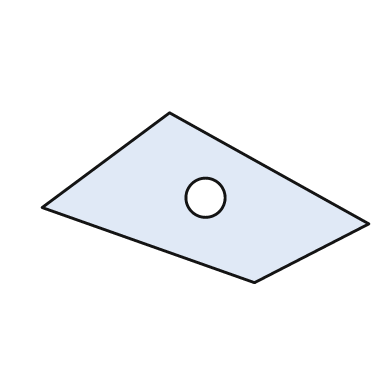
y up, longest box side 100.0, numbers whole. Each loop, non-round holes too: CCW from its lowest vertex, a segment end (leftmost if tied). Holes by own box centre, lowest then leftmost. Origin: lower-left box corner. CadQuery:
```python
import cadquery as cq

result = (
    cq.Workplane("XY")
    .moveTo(65.0, 0.0)
    .lineTo(100.0, 18.0)
    .lineTo(39.0, 52.0)
    .lineTo(0.0, 23.0)
    .close()
    .moveTo(50.0, 26.0)
    .circle(6.0)
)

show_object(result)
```